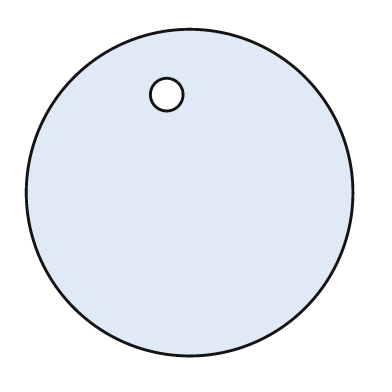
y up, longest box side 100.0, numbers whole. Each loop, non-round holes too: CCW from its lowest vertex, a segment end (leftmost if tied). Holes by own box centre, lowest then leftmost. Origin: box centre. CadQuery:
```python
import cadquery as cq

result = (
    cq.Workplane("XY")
    .moveTo(0.0, 0.0)
    .circle(50.0)
    .moveTo(-7.0, 30.0)
    .circle(5.0)
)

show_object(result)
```